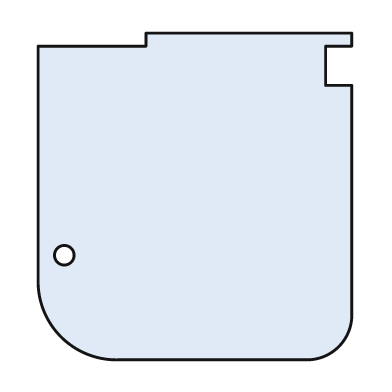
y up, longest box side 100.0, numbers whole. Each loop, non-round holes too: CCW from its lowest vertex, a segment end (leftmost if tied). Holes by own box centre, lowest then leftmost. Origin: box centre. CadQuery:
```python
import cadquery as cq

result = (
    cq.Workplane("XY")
    .moveTo(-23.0, -50.0)
    .lineTo(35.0, -50.0)
    .threePointArc((44.0, -46.0), (48.0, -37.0))
    .lineTo(48.0, 34.0)
    .lineTo(40.0, 34.0)
    .lineTo(40.0, 46.0)
    .lineTo(48.0, 46.0)
    .lineTo(48.0, 50.0)
    .lineTo(-15.0, 50.0)
    .lineTo(-15.0, 46.0)
    .lineTo(-48.0, 46.0)
    .lineTo(-48.0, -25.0)
    .threePointArc((-41.0, -43.0), (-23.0, -50.0))
    .close()
    .moveTo(-40.0, -18.0)
    .circle(3.0)
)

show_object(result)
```